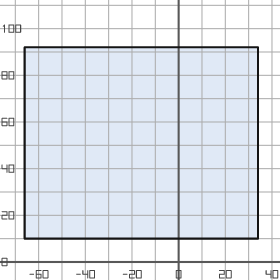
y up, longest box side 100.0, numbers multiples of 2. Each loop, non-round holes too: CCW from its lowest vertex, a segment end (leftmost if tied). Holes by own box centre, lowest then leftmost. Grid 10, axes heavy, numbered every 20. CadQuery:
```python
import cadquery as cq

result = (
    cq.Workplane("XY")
    .moveTo(-66.0, 10.0)
    .lineTo(34.0, 10.0)
    .lineTo(34.0, 92.0)
    .lineTo(-66.0, 92.0)
    .close()
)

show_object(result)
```